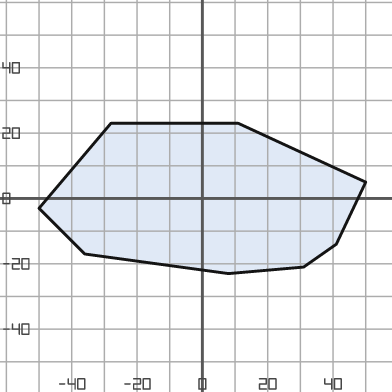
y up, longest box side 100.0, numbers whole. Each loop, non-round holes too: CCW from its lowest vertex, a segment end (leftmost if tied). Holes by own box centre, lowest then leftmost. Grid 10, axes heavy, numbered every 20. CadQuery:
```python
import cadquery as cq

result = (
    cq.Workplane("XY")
    .moveTo(8.0, -23.0)
    .lineTo(31.0, -21.0)
    .lineTo(41.0, -14.0)
    .lineTo(50.0, 5.0)
    .lineTo(11.0, 23.0)
    .lineTo(-28.0, 23.0)
    .lineTo(-50.0, -3.0)
    .lineTo(-36.0, -17.0)
    .close()
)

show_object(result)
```